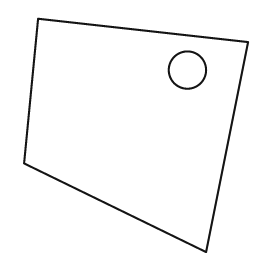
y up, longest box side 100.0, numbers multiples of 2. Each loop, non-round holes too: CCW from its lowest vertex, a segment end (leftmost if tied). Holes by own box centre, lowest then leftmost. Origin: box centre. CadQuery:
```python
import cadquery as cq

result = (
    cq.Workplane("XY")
    .moveTo(30.0, -50.0)
    .lineTo(48.0, 40.0)
    .lineTo(-42.0, 50.0)
    .lineTo(-48.0, -12.0)
    .close()
    .moveTo(22.0, 28.0)
    .circle(8.0)
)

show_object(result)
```